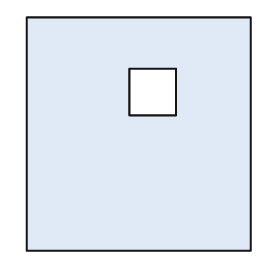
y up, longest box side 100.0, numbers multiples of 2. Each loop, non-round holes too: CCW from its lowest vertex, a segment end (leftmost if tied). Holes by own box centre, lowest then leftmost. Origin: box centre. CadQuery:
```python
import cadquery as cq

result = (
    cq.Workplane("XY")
    .moveTo(-48.0, -50.0)
    .lineTo(48.0, -50.0)
    .lineTo(48.0, 50.0)
    .lineTo(-48.0, 50.0)
    .close()
    .moveTo(-4.0, 8.0)
    .lineTo(16.0, 8.0)
    .lineTo(16.0, 28.0)
    .lineTo(-4.0, 28.0)
    .close()
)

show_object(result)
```